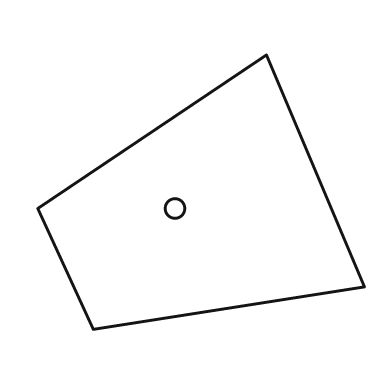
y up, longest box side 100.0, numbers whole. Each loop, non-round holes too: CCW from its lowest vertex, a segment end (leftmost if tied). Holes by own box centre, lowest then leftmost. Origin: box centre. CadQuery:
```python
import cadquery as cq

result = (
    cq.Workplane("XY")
    .moveTo(-33.0, -42.0)
    .lineTo(50.0, -29.0)
    .lineTo(20.0, 42.0)
    .lineTo(-50.0, -5.0)
    .close()
    .moveTo(-8.0, -5.0)
    .circle(3.0)
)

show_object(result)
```